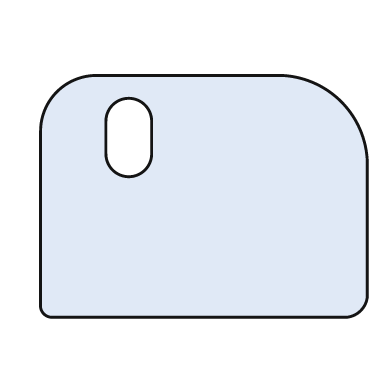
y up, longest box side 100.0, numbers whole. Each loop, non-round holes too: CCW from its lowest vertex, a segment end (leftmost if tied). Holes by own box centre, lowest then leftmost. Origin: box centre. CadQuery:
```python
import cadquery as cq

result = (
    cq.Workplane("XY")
    .moveTo(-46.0, -37.0)
    .lineTo(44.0, -37.0)
    .threePointArc((48.0, -35.0), (50.0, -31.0))
    .lineTo(50.0, 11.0)
    .threePointArc((42.0, 29.0), (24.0, 37.0))
    .lineTo(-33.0, 37.0)
    .threePointArc((-45.0, 32.0), (-50.0, 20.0))
    .lineTo(-50.0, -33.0)
    .threePointArc((-49.0, -36.0), (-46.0, -37.0))
    .close()
    .moveTo(-30.0, 13.0)
    .threePointArc((-23.0, 6.0), (-16.0, 13.0))
    .lineTo(-16.0, 23.0)
    .threePointArc((-23.0, 30.0), (-30.0, 23.0))
    .close()
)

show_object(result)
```